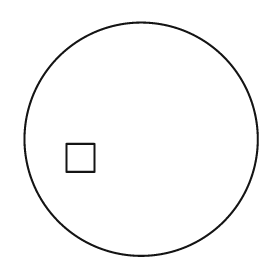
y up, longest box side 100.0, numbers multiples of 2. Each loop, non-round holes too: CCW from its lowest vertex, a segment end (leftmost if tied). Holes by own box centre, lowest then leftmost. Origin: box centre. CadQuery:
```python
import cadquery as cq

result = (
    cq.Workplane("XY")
    .moveTo(0.0, 0.0)
    .circle(50.0)
    .moveTo(-32.0, -14.0)
    .lineTo(-20.0, -14.0)
    .lineTo(-20.0, -2.0)
    .lineTo(-32.0, -2.0)
    .close()
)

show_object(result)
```